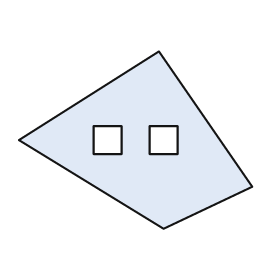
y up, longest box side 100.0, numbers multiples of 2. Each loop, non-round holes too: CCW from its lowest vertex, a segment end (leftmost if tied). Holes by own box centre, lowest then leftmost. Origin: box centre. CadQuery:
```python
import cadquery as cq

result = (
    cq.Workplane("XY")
    .moveTo(12.0, -38.0)
    .lineTo(50.0, -20.0)
    .lineTo(10.0, 38.0)
    .lineTo(-50.0, 0.0)
    .close()
    .moveTo(-18.0, -6.0)
    .lineTo(-6.0, -6.0)
    .lineTo(-6.0, 6.0)
    .lineTo(-18.0, 6.0)
    .close()
    .moveTo(6.0, -6.0)
    .lineTo(18.0, -6.0)
    .lineTo(18.0, 6.0)
    .lineTo(6.0, 6.0)
    .close()
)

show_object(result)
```